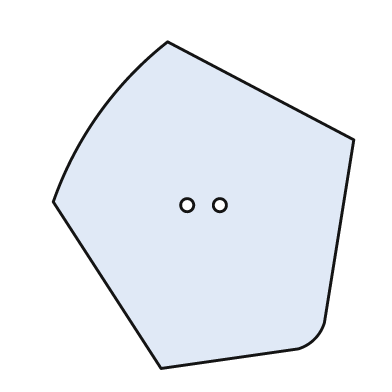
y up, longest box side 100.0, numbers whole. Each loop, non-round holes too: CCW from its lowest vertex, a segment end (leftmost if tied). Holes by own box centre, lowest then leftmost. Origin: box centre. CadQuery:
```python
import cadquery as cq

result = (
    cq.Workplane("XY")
    .moveTo(-13.0, -50.0)
    .lineTo(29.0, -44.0)
    .threePointArc((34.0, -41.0), (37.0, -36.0))
    .lineTo(46.0, 20.0)
    .lineTo(-11.0, 50.0)
    .threePointArc((-32.0, 28.0), (-46.0, 1.0))
    .close()
    .moveTo(-5.0, 0.0)
    .circle(2.0)
    .moveTo(5.0, 0.0)
    .circle(2.0)
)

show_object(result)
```